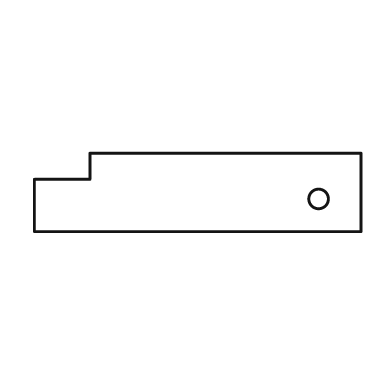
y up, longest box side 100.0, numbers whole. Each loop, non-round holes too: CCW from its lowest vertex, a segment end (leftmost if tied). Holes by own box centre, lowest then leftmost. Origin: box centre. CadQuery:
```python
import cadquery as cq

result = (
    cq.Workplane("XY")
    .moveTo(-50.0, -12.0)
    .lineTo(50.0, -12.0)
    .lineTo(50.0, 12.0)
    .lineTo(-33.0, 12.0)
    .lineTo(-33.0, 4.0)
    .lineTo(-50.0, 4.0)
    .close()
    .moveTo(37.0, -2.0)
    .circle(3.0)
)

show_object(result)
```